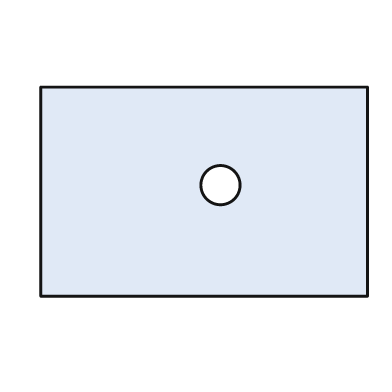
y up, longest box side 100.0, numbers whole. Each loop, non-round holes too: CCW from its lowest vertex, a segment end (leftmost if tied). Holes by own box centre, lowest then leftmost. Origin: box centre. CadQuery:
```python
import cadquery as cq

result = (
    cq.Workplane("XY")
    .moveTo(-50.0, -32.0)
    .lineTo(50.0, -32.0)
    .lineTo(50.0, 32.0)
    .lineTo(-50.0, 32.0)
    .close()
    .moveTo(5.0, 2.0)
    .circle(6.0)
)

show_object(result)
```